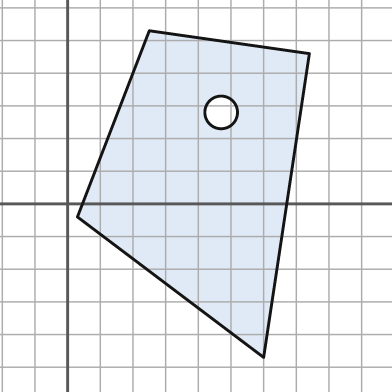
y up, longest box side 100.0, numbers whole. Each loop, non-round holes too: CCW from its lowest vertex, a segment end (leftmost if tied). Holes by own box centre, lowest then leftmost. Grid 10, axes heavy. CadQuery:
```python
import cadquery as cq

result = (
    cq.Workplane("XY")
    .moveTo(60.0, -47.0)
    .lineTo(74.0, 46.0)
    .lineTo(25.0, 53.0)
    .lineTo(3.0, -4.0)
    .close()
    .moveTo(47.0, 28.0)
    .circle(5.0)
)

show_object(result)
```